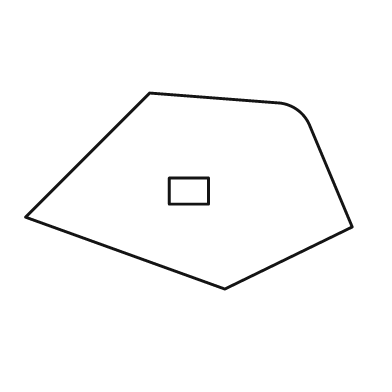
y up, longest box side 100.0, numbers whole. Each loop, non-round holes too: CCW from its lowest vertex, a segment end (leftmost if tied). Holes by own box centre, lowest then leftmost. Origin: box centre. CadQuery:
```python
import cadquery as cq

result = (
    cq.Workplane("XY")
    .moveTo(11.0, -30.0)
    .lineTo(50.0, -11.0)
    .lineTo(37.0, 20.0)
    .threePointArc((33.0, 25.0), (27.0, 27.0))
    .lineTo(-12.0, 30.0)
    .lineTo(-50.0, -8.0)
    .close()
    .moveTo(-6.0, -4.0)
    .lineTo(6.0, -4.0)
    .lineTo(6.0, 4.0)
    .lineTo(-6.0, 4.0)
    .close()
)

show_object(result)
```